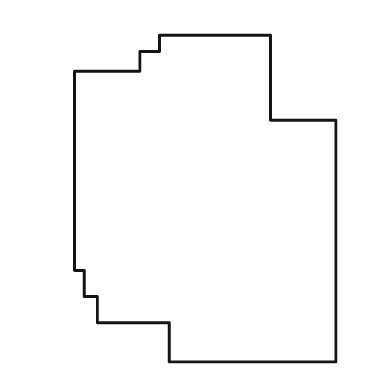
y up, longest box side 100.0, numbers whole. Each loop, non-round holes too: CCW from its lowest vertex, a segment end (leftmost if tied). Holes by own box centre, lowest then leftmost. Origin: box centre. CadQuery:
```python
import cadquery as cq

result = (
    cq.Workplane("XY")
    .moveTo(-11.0, -50.0)
    .lineTo(40.0, -50.0)
    .lineTo(40.0, 24.0)
    .lineTo(20.0, 24.0)
    .lineTo(20.0, 50.0)
    .lineTo(-14.0, 50.0)
    .lineTo(-14.0, 45.0)
    .lineTo(-20.0, 45.0)
    .lineTo(-20.0, 39.0)
    .lineTo(-40.0, 39.0)
    .lineTo(-40.0, -22.0)
    .lineTo(-37.0, -22.0)
    .lineTo(-37.0, -30.0)
    .lineTo(-33.0, -30.0)
    .lineTo(-33.0, -38.0)
    .lineTo(-11.0, -38.0)
    .close()
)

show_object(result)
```